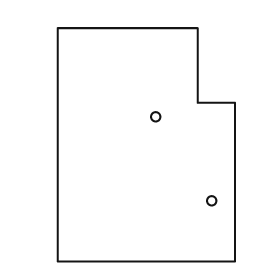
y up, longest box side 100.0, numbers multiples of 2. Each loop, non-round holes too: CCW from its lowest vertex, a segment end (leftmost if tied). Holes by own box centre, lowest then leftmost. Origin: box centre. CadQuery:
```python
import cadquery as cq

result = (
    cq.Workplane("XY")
    .moveTo(-38.0, -50.0)
    .lineTo(38.0, -50.0)
    .lineTo(38.0, 18.0)
    .lineTo(22.0, 18.0)
    .lineTo(22.0, 50.0)
    .lineTo(-38.0, 50.0)
    .close()
    .moveTo(28.0, -24.0)
    .circle(2.0)
    .moveTo(4.0, 12.0)
    .circle(2.0)
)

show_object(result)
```